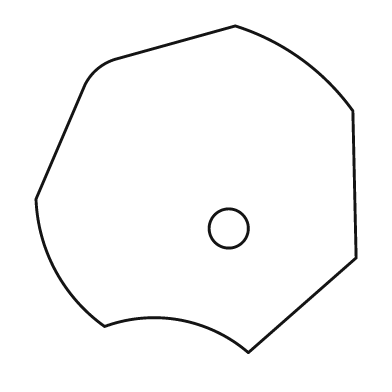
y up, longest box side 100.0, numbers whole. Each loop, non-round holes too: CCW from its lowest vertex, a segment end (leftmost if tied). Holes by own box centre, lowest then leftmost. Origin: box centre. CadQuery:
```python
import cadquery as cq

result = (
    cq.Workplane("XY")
    .moveTo(16.0, -50.0)
    .lineTo(49.0, -21.0)
    .lineTo(48.0, 24.0)
    .threePointArc((32.0, 40.0), (12.0, 50.0))
    .lineTo(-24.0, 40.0)
    .threePointArc((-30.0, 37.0), (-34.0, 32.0))
    .lineTo(-49.0, -3.0)
    .threePointArc((-43.0, -25.0), (-28.0, -42.0))
    .threePointArc((-5.0, -40.0), (16.0, -50.0))
    .close()
    .moveTo(10.0, -12.0)
    .circle(6.0)
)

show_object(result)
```